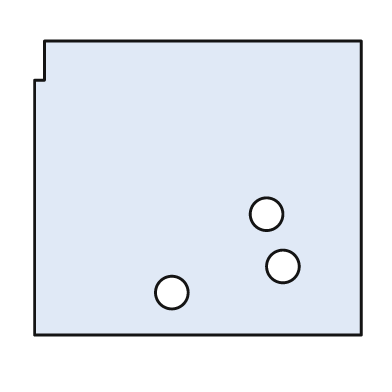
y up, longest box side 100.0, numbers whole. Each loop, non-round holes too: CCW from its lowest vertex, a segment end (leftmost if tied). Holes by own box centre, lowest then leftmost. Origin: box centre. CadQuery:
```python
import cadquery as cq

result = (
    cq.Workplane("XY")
    .moveTo(-50.0, -45.0)
    .lineTo(50.0, -45.0)
    .lineTo(50.0, 45.0)
    .lineTo(-47.0, 45.0)
    .lineTo(-47.0, 33.0)
    .lineTo(-50.0, 33.0)
    .close()
    .moveTo(-8.0, -32.0)
    .circle(5.0)
    .moveTo(26.0, -24.0)
    .circle(5.0)
    .moveTo(21.0, -8.0)
    .circle(5.0)
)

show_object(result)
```